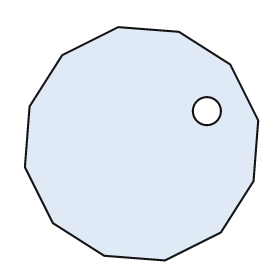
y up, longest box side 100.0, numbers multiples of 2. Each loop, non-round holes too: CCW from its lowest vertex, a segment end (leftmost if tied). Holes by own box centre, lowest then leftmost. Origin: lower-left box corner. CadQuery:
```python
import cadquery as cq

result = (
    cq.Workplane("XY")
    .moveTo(60.0, 0.0)
    .lineTo(84.0, 12.0)
    .lineTo(98.0, 34.0)
    .lineTo(100.0, 60.0)
    .lineTo(88.0, 84.0)
    .lineTo(66.0, 98.0)
    .lineTo(40.0, 100.0)
    .lineTo(16.0, 88.0)
    .lineTo(2.0, 66.0)
    .lineTo(0.0, 40.0)
    .lineTo(12.0, 16.0)
    .lineTo(34.0, 2.0)
    .close()
    .moveTo(78.0, 64.0)
    .circle(6.0)
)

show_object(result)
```